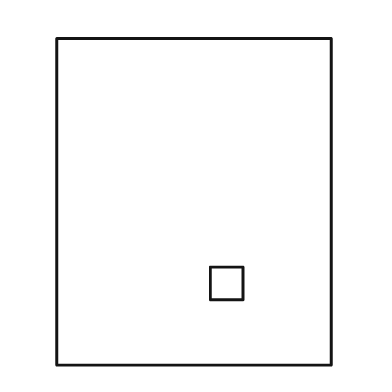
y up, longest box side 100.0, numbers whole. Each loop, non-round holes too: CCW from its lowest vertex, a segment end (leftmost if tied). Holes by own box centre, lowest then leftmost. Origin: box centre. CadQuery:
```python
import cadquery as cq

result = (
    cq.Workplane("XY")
    .moveTo(-42.0, -50.0)
    .lineTo(42.0, -50.0)
    .lineTo(42.0, 50.0)
    .lineTo(-42.0, 50.0)
    .close()
    .moveTo(5.0, -30.0)
    .lineTo(15.0, -30.0)
    .lineTo(15.0, -20.0)
    .lineTo(5.0, -20.0)
    .close()
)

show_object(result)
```